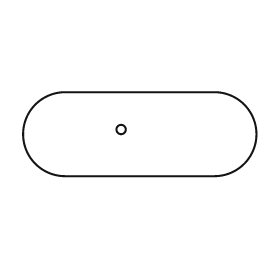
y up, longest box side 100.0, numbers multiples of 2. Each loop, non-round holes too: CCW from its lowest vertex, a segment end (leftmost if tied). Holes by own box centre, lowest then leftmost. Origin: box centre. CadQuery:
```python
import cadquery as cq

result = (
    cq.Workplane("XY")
    .moveTo(-32.0, -18.0)
    .lineTo(32.0, -18.0)
    .threePointArc((50.0, 0.0), (32.0, 18.0))
    .lineTo(-32.0, 18.0)
    .threePointArc((-50.0, 0.0), (-32.0, -18.0))
    .close()
    .moveTo(-8.0, 2.0)
    .circle(2.0)
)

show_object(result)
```